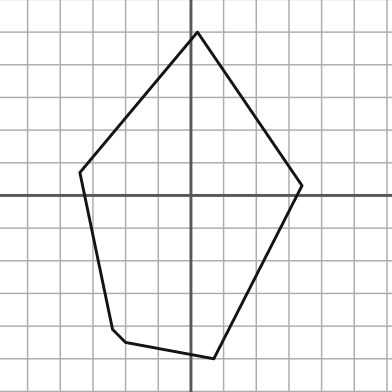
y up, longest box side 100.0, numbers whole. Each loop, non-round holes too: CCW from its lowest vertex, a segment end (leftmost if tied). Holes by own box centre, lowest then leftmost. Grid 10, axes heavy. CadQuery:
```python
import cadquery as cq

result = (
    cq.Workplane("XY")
    .moveTo(7.0, -50.0)
    .lineTo(34.0, 3.0)
    .lineTo(2.0, 50.0)
    .lineTo(-34.0, 7.0)
    .lineTo(-24.0, -41.0)
    .lineTo(-20.0, -45.0)
    .close()
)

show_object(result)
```